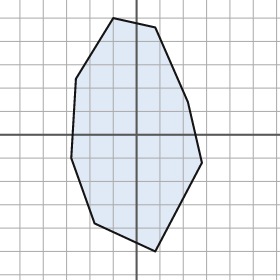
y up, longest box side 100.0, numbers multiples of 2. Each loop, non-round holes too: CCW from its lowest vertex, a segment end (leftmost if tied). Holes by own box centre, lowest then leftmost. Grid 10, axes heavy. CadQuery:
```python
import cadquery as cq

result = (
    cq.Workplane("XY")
    .moveTo(8.0, -50.0)
    .lineTo(28.0, -12.0)
    .lineTo(22.0, 14.0)
    .lineTo(8.0, 46.0)
    .lineTo(-10.0, 50.0)
    .lineTo(-26.0, 24.0)
    .lineTo(-28.0, -10.0)
    .lineTo(-18.0, -38.0)
    .close()
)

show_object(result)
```